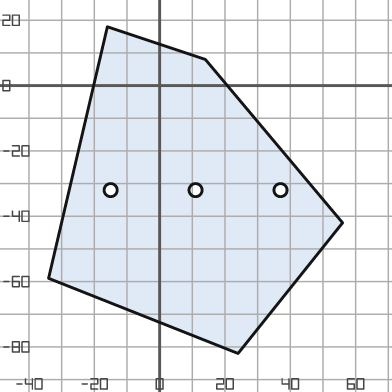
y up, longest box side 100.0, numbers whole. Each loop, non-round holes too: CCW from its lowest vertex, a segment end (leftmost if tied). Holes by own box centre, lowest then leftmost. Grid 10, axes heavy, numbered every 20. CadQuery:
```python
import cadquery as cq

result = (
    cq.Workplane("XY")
    .moveTo(24.0, -82.0)
    .lineTo(56.0, -42.0)
    .lineTo(14.0, 8.0)
    .lineTo(-16.0, 18.0)
    .lineTo(-34.0, -59.0)
    .close()
    .moveTo(-15.0, -32.0)
    .circle(2.0)
    .moveTo(11.0, -32.0)
    .circle(2.0)
    .moveTo(37.0, -32.0)
    .circle(2.0)
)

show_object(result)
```